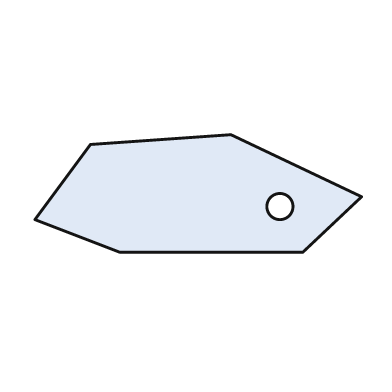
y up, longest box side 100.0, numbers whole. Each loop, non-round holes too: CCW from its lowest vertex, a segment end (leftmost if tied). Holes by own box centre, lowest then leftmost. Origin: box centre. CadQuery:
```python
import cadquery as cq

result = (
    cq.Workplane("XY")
    .moveTo(-24.0, -18.0)
    .lineTo(32.0, -18.0)
    .lineTo(50.0, -1.0)
    .lineTo(10.0, 18.0)
    .lineTo(-33.0, 15.0)
    .lineTo(-50.0, -8.0)
    .close()
    .moveTo(25.0, -4.0)
    .circle(4.0)
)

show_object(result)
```